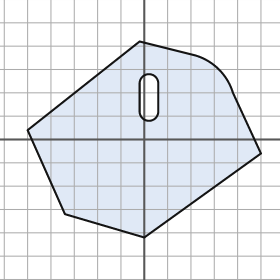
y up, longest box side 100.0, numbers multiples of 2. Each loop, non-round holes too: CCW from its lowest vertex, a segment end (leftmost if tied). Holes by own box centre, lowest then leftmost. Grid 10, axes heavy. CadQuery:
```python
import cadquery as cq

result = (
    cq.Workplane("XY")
    .moveTo(0.0, -42.0)
    .lineTo(50.0, -6.0)
    .lineTo(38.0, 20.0)
    .threePointArc((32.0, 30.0), (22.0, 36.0))
    .lineTo(-2.0, 42.0)
    .lineTo(-50.0, 4.0)
    .lineTo(-34.0, -32.0)
    .close()
    .moveTo(-2.0, 12.0)
    .threePointArc((2.0, 8.0), (6.0, 12.0))
    .lineTo(6.0, 24.0)
    .threePointArc((2.0, 28.0), (-2.0, 24.0))
    .close()
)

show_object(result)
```